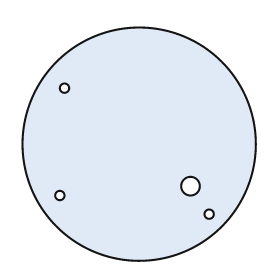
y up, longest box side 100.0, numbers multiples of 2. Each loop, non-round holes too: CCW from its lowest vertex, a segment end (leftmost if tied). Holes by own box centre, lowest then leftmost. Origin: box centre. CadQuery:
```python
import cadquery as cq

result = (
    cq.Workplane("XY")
    .moveTo(0.0, 0.0)
    .circle(50.0)
    .moveTo(30.0, -30.0)
    .circle(2.0)
    .moveTo(-34.0, -22.0)
    .circle(2.0)
    .moveTo(22.0, -18.0)
    .circle(4.0)
    .moveTo(-32.0, 24.0)
    .circle(2.0)
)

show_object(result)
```